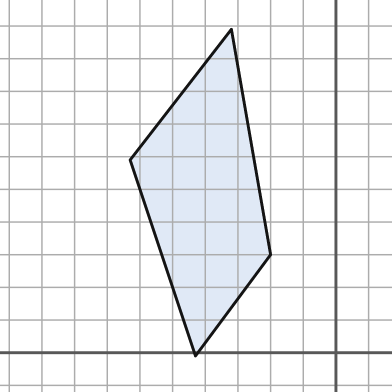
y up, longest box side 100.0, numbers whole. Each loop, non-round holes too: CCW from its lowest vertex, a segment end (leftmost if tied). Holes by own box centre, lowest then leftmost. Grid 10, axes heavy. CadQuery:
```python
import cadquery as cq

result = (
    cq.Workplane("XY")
    .moveTo(-43.0, -1.0)
    .lineTo(-20.0, 30.0)
    .lineTo(-32.0, 99.0)
    .lineTo(-63.0, 59.0)
    .close()
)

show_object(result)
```